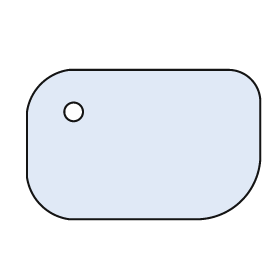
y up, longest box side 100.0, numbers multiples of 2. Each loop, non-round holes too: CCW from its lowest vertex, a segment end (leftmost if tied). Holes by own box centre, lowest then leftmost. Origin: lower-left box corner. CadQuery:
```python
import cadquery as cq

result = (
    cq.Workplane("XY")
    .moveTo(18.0, 0.0)
    .lineTo(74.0, 0.0)
    .threePointArc((92.0, 8.0), (100.0, 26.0))
    .lineTo(100.0, 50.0)
    .threePointArc((96.0, 60.0), (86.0, 64.0))
    .lineTo(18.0, 64.0)
    .threePointArc((6.0, 58.0), (0.0, 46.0))
    .lineTo(0.0, 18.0)
    .threePointArc((6.0, 6.0), (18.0, 0.0))
    .close()
    .moveTo(20.0, 46.0)
    .circle(4.0)
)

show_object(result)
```